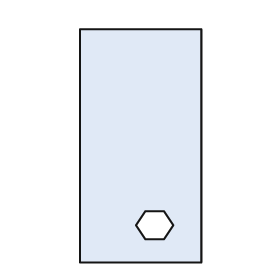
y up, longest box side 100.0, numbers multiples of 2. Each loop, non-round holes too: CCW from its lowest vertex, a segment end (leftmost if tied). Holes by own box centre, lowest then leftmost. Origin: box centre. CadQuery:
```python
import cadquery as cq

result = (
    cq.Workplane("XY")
    .moveTo(-26.0, -50.0)
    .lineTo(26.0, -50.0)
    .lineTo(26.0, 50.0)
    .lineTo(-26.0, 50.0)
    .close()
    .moveTo(2.0, -40.0)
    .lineTo(10.0, -40.0)
    .lineTo(14.0, -34.0)
    .lineTo(10.0, -28.0)
    .lineTo(2.0, -28.0)
    .lineTo(-2.0, -34.0)
    .close()
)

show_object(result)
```